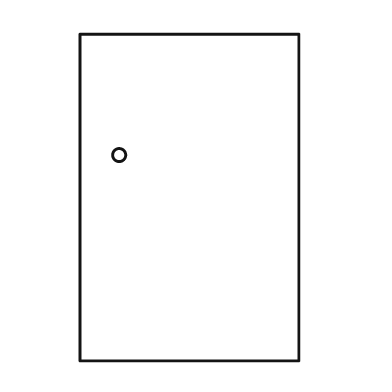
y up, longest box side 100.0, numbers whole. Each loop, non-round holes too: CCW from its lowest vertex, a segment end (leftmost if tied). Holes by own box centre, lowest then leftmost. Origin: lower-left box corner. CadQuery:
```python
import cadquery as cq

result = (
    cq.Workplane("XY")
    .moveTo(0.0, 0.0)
    .lineTo(67.0, 0.0)
    .lineTo(67.0, 100.0)
    .lineTo(0.0, 100.0)
    .close()
    .moveTo(12.0, 63.0)
    .circle(2.0)
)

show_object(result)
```